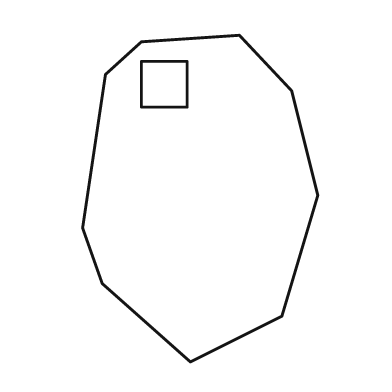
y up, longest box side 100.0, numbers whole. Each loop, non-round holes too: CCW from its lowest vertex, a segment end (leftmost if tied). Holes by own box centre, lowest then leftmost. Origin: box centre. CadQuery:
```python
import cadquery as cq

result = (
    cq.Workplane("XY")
    .moveTo(-3.0, -50.0)
    .lineTo(25.0, -36.0)
    .lineTo(36.0, 1.0)
    .lineTo(28.0, 33.0)
    .lineTo(12.0, 50.0)
    .lineTo(-18.0, 48.0)
    .lineTo(-29.0, 38.0)
    .lineTo(-36.0, -9.0)
    .lineTo(-30.0, -26.0)
    .close()
    .moveTo(-18.0, 28.0)
    .lineTo(-4.0, 28.0)
    .lineTo(-4.0, 42.0)
    .lineTo(-18.0, 42.0)
    .close()
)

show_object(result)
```